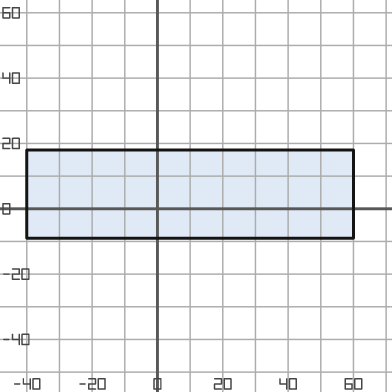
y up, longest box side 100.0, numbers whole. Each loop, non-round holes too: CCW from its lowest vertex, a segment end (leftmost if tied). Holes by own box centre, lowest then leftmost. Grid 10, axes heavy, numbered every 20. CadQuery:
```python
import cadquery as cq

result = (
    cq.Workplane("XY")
    .moveTo(-40.0, -9.0)
    .lineTo(60.0, -9.0)
    .lineTo(60.0, 18.0)
    .lineTo(-40.0, 18.0)
    .close()
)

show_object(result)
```